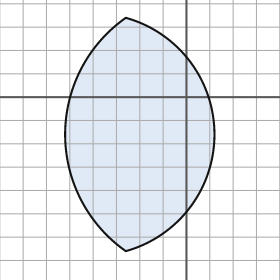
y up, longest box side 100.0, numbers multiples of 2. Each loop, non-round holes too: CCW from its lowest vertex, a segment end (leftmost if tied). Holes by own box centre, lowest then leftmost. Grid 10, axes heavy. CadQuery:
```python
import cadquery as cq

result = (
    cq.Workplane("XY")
    .moveTo(-26.0, -66.0)
    .threePointArc((12.0, -16.0), (-26.0, 34.0))
    .threePointArc((-52.0, -16.0), (-26.0, -66.0))
    .close()
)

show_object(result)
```